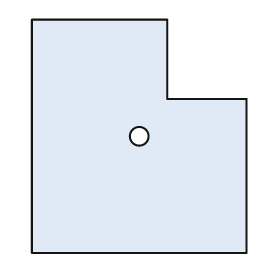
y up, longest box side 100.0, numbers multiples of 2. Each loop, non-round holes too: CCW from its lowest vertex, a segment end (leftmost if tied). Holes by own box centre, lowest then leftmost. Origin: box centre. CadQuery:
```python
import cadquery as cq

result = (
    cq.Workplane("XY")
    .moveTo(-46.0, -50.0)
    .lineTo(46.0, -50.0)
    .lineTo(46.0, 16.0)
    .lineTo(12.0, 16.0)
    .lineTo(12.0, 50.0)
    .lineTo(-46.0, 50.0)
    .close()
    .moveTo(0.0, 0.0)
    .circle(4.0)
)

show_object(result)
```